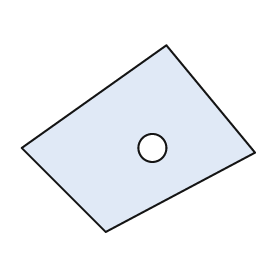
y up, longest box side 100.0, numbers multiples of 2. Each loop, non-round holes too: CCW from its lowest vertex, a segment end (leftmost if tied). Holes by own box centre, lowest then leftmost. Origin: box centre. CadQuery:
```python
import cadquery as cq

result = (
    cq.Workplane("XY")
    .moveTo(-14.0, -40.0)
    .lineTo(50.0, -6.0)
    .lineTo(12.0, 40.0)
    .lineTo(-50.0, -4.0)
    .close()
    .moveTo(6.0, -4.0)
    .circle(6.0)
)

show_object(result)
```